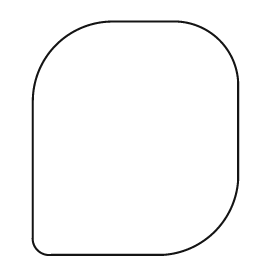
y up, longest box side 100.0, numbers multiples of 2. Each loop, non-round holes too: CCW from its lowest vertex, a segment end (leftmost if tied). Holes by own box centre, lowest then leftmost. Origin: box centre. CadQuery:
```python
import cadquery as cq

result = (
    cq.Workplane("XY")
    .moveTo(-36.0, -50.0)
    .lineTo(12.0, -50.0)
    .threePointArc((34.0, -40.0), (44.0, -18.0))
    .lineTo(44.0, 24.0)
    .threePointArc((36.0, 42.0), (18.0, 50.0))
    .lineTo(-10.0, 50.0)
    .threePointArc((-34.0, 40.0), (-44.0, 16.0))
    .lineTo(-44.0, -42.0)
    .threePointArc((-42.0, -48.0), (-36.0, -50.0))
    .close()
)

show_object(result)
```